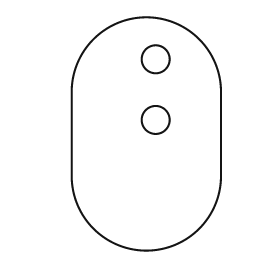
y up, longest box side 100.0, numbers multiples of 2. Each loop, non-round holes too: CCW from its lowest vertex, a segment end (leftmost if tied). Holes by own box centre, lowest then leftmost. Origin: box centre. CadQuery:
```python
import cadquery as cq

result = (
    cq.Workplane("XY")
    .moveTo(-32.0, -18.0)
    .threePointArc((0.0, -50.0), (32.0, -18.0))
    .lineTo(32.0, 18.0)
    .threePointArc((0.0, 50.0), (-32.0, 18.0))
    .close()
    .moveTo(4.0, 6.0)
    .circle(6.0)
    .moveTo(4.0, 32.0)
    .circle(6.0)
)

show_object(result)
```